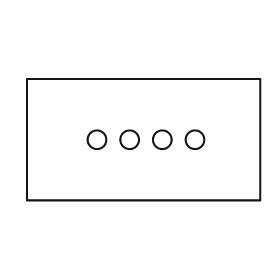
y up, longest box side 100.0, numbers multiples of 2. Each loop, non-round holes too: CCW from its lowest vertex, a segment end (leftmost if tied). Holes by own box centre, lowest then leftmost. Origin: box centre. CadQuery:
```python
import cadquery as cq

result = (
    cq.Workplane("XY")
    .moveTo(-50.0, -26.0)
    .lineTo(50.0, -26.0)
    .lineTo(50.0, 26.0)
    .lineTo(-50.0, 26.0)
    .close()
    .moveTo(-20.0, 0.0)
    .circle(4.0)
    .moveTo(-6.0, 0.0)
    .circle(4.0)
    .moveTo(8.0, 0.0)
    .circle(4.0)
    .moveTo(22.0, 0.0)
    .circle(4.0)
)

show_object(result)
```